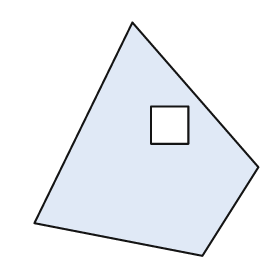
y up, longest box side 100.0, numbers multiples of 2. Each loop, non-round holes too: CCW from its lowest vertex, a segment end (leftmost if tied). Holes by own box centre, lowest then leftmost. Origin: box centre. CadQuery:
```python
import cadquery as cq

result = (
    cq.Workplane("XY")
    .moveTo(24.0, -50.0)
    .lineTo(48.0, -12.0)
    .lineTo(-6.0, 50.0)
    .lineTo(-48.0, -36.0)
    .close()
    .moveTo(2.0, -2.0)
    .lineTo(18.0, -2.0)
    .lineTo(18.0, 14.0)
    .lineTo(2.0, 14.0)
    .close()
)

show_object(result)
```